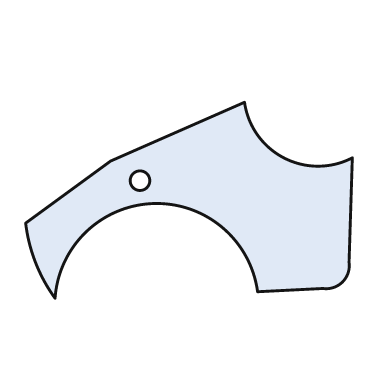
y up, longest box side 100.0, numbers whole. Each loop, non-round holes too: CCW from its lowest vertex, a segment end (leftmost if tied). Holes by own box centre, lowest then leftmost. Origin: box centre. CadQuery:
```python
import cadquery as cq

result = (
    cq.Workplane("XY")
    .moveTo(-41.0, -30.0)
    .threePointArc((-11.0, -1.0), (21.0, -28.0))
    .lineTo(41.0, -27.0)
    .threePointArc((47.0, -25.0), (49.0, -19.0))
    .lineTo(50.0, 13.0)
    .threePointArc((29.0, 13.0), (17.0, 30.0))
    .lineTo(-24.0, 12.0)
    .lineTo(-50.0, -7.0)
    .threePointArc((-47.0, -19.0), (-41.0, -30.0))
    .close()
    .moveTo(-15.0, 6.0)
    .circle(3.0)
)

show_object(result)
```